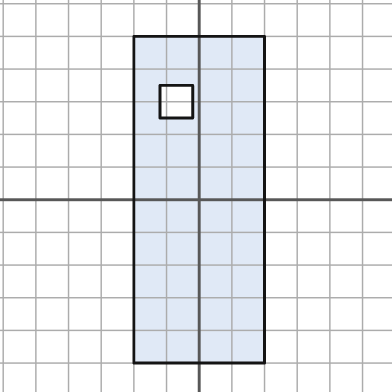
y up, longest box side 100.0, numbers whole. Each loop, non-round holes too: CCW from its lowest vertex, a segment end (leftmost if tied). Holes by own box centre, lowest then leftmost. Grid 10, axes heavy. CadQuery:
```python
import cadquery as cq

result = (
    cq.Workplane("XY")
    .moveTo(-20.0, -50.0)
    .lineTo(20.0, -50.0)
    .lineTo(20.0, 50.0)
    .lineTo(-20.0, 50.0)
    .close()
    .moveTo(-12.0, 25.0)
    .lineTo(-2.0, 25.0)
    .lineTo(-2.0, 35.0)
    .lineTo(-12.0, 35.0)
    .close()
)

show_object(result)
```